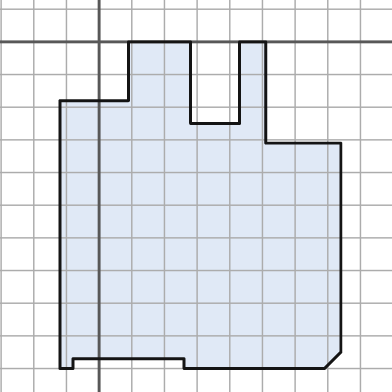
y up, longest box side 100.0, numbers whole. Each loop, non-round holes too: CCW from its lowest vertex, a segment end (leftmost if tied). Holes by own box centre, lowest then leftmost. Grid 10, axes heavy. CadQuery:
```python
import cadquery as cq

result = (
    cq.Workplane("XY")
    .moveTo(-12.0, -100.0)
    .lineTo(-8.0, -100.0)
    .lineTo(-8.0, -97.0)
    .lineTo(26.0, -97.0)
    .lineTo(26.0, -100.0)
    .lineTo(69.0, -100.0)
    .lineTo(74.0, -95.0)
    .lineTo(74.0, -31.0)
    .lineTo(51.0, -31.0)
    .lineTo(51.0, 0.0)
    .lineTo(43.0, 0.0)
    .lineTo(43.0, -25.0)
    .lineTo(28.0, -25.0)
    .lineTo(28.0, 0.0)
    .lineTo(9.0, 0.0)
    .lineTo(9.0, -18.0)
    .lineTo(-12.0, -18.0)
    .close()
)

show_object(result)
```